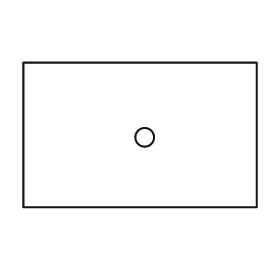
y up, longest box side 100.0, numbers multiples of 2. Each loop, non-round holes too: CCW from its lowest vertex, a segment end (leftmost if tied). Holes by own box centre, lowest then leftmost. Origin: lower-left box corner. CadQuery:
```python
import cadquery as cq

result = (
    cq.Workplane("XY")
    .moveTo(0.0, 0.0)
    .lineTo(100.0, 0.0)
    .lineTo(100.0, 62.0)
    .lineTo(0.0, 62.0)
    .close()
    .moveTo(52.0, 30.0)
    .circle(4.0)
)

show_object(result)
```